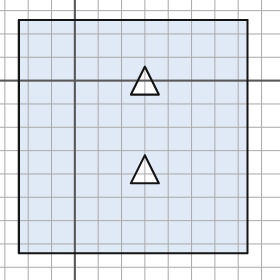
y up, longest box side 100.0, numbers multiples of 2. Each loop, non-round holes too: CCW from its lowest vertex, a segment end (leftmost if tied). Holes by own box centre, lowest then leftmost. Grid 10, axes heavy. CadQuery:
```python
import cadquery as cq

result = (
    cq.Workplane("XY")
    .moveTo(-24.0, -74.0)
    .lineTo(74.0, -74.0)
    .lineTo(74.0, 26.0)
    .lineTo(-24.0, 26.0)
    .close()
    .moveTo(24.0, -44.0)
    .lineTo(36.0, -44.0)
    .lineTo(30.0, -32.0)
    .close()
    .moveTo(24.0, -6.0)
    .lineTo(36.0, -6.0)
    .lineTo(30.0, 6.0)
    .close()
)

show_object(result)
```